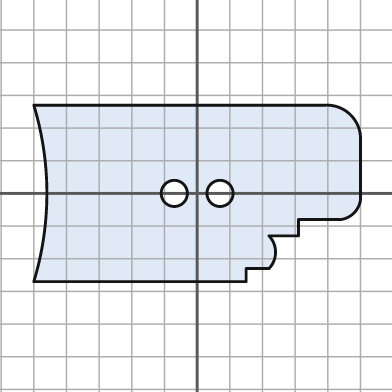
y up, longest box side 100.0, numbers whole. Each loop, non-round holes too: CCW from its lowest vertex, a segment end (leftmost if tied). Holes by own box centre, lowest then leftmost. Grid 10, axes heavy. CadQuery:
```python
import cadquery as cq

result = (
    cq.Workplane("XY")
    .moveTo(-50.0, -27.0)
    .lineTo(15.0, -27.0)
    .lineTo(15.0, -23.0)
    .lineTo(22.0, -23.0)
    .threePointArc((24.0, -18.0), (22.0, -13.0))
    .lineTo(31.0, -13.0)
    .lineTo(31.0, -8.0)
    .lineTo(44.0, -8.0)
    .threePointArc((48.0, -6.0), (50.0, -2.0))
    .lineTo(50.0, 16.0)
    .threePointArc((47.0, 24.0), (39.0, 27.0))
    .lineTo(-50.0, 27.0)
    .threePointArc((-46.0, 0.0), (-50.0, -27.0))
    .close()
    .moveTo(-7.0, 0.0)
    .circle(4.0)
    .moveTo(7.0, 0.0)
    .circle(4.0)
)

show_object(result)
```